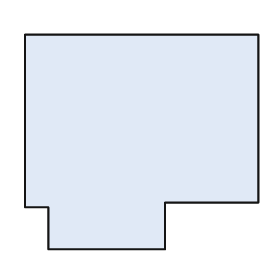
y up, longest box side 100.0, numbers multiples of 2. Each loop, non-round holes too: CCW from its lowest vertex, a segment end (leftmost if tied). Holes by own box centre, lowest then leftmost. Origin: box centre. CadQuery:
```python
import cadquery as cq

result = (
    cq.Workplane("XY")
    .moveTo(-40.0, -46.0)
    .lineTo(10.0, -46.0)
    .lineTo(10.0, -26.0)
    .lineTo(50.0, -26.0)
    .lineTo(50.0, 46.0)
    .lineTo(-50.0, 46.0)
    .lineTo(-50.0, -28.0)
    .lineTo(-40.0, -28.0)
    .close()
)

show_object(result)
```